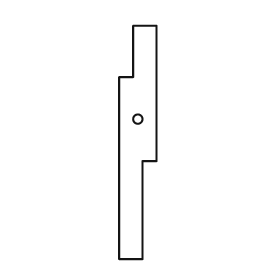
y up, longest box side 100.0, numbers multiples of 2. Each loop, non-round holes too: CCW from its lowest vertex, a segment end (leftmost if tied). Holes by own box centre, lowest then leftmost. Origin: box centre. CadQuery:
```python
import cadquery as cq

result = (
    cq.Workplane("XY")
    .moveTo(-8.0, -50.0)
    .lineTo(2.0, -50.0)
    .lineTo(2.0, -8.0)
    .lineTo(8.0, -8.0)
    .lineTo(8.0, 50.0)
    .lineTo(-2.0, 50.0)
    .lineTo(-2.0, 28.0)
    .lineTo(-8.0, 28.0)
    .close()
    .moveTo(0.0, 10.0)
    .circle(2.0)
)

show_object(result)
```